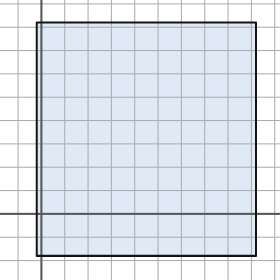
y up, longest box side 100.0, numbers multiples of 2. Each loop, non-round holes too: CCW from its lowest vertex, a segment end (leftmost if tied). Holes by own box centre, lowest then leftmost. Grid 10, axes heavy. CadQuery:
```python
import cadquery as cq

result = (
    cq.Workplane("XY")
    .moveTo(-2.0, -18.0)
    .lineTo(92.0, -18.0)
    .lineTo(92.0, 82.0)
    .lineTo(-2.0, 82.0)
    .close()
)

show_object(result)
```